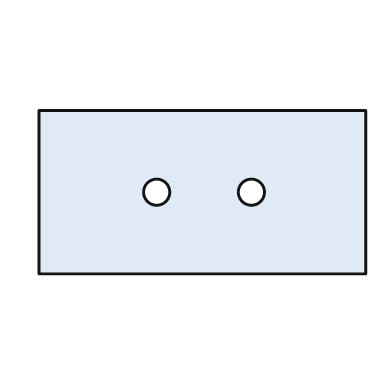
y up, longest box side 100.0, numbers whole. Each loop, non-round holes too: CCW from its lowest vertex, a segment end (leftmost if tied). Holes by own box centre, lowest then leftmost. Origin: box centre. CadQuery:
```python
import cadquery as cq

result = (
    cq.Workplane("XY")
    .moveTo(-50.0, -25.0)
    .lineTo(50.0, -25.0)
    .lineTo(50.0, 25.0)
    .lineTo(-50.0, 25.0)
    .close()
    .moveTo(-14.0, 0.0)
    .circle(4.0)
    .moveTo(15.0, 0.0)
    .circle(4.0)
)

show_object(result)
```